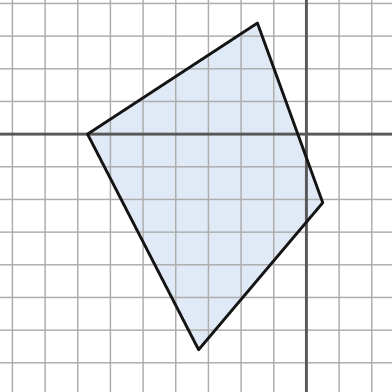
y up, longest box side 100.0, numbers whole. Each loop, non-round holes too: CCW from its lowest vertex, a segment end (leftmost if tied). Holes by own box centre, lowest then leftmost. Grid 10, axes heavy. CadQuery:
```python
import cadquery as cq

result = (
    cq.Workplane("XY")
    .moveTo(-33.0, -66.0)
    .lineTo(5.0, -21.0)
    .lineTo(-15.0, 34.0)
    .lineTo(-67.0, 0.0)
    .close()
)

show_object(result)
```